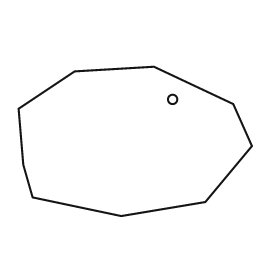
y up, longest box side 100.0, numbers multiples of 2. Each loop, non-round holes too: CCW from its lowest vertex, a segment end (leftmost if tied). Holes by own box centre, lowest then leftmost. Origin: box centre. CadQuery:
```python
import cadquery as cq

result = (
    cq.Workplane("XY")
    .moveTo(-6.0, -32.0)
    .lineTo(30.0, -26.0)
    .lineTo(50.0, -2.0)
    .lineTo(42.0, 16.0)
    .lineTo(8.0, 32.0)
    .lineTo(-26.0, 30.0)
    .lineTo(-50.0, 14.0)
    .lineTo(-48.0, -10.0)
    .lineTo(-44.0, -24.0)
    .close()
    .moveTo(16.0, 18.0)
    .circle(2.0)
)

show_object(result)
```